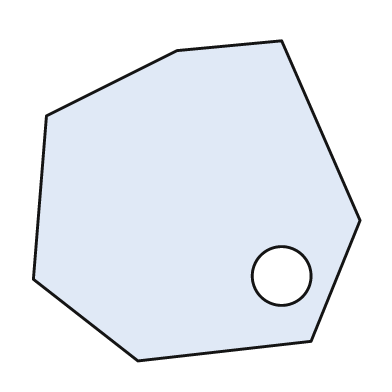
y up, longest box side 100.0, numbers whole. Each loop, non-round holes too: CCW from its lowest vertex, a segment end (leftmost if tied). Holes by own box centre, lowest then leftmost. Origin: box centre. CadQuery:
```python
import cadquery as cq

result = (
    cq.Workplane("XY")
    .moveTo(-18.0, -49.0)
    .lineTo(35.0, -43.0)
    .lineTo(50.0, -6.0)
    .lineTo(26.0, 49.0)
    .lineTo(-6.0, 46.0)
    .lineTo(-46.0, 26.0)
    .lineTo(-50.0, -24.0)
    .close()
    .moveTo(26.0, -23.0)
    .circle(9.0)
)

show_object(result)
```